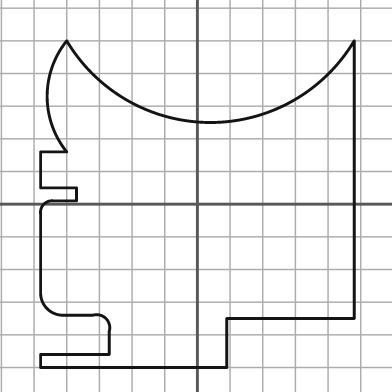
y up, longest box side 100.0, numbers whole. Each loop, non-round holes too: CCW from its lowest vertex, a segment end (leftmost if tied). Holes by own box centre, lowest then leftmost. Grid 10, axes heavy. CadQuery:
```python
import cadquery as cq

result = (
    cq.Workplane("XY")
    .moveTo(-48.0, -50.0)
    .lineTo(9.0, -50.0)
    .lineTo(9.0, -35.0)
    .lineTo(48.0, -35.0)
    .lineTo(48.0, 50.0)
    .threePointArc((4.0, 25.0), (-40.0, 50.0))
    .threePointArc((-46.0, 33.0), (-40.0, 16.0))
    .lineTo(-48.0, 16.0)
    .lineTo(-48.0, 5.0)
    .lineTo(-37.0, 5.0)
    .lineTo(-37.0, 1.0)
    .lineTo(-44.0, 1.0)
    .threePointArc((-47.0, 0.0), (-48.0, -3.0))
    .lineTo(-48.0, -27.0)
    .threePointArc((-46.0, -32.0), (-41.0, -34.0))
    .lineTo(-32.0, -34.0)
    .threePointArc((-28.0, -35.0), (-27.0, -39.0))
    .lineTo(-27.0, -46.0)
    .lineTo(-48.0, -46.0)
    .close()
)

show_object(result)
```